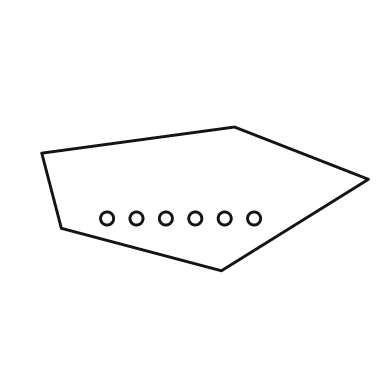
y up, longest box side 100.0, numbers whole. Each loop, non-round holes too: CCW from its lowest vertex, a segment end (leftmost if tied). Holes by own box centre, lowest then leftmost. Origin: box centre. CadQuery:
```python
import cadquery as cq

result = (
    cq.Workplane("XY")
    .moveTo(5.0, -22.0)
    .lineTo(50.0, 6.0)
    .lineTo(9.0, 22.0)
    .lineTo(-50.0, 14.0)
    .lineTo(-44.0, -9.0)
    .close()
    .moveTo(-30.0, -6.0)
    .circle(2.0)
    .moveTo(-21.0, -6.0)
    .circle(2.0)
    .moveTo(-12.0, -6.0)
    .circle(2.0)
    .moveTo(-3.0, -6.0)
    .circle(2.0)
    .moveTo(6.0, -6.0)
    .circle(2.0)
    .moveTo(15.0, -6.0)
    .circle(2.0)
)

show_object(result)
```